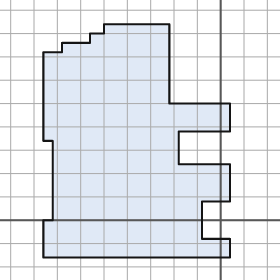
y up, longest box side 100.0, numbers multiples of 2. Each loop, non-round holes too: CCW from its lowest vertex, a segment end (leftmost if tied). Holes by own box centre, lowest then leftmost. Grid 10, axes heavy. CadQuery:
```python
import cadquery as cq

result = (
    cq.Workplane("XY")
    .moveTo(-76.0, -16.0)
    .lineTo(4.0, -16.0)
    .lineTo(4.0, -8.0)
    .lineTo(-8.0, -8.0)
    .lineTo(-8.0, 8.0)
    .lineTo(4.0, 8.0)
    .lineTo(4.0, 24.0)
    .lineTo(-18.0, 24.0)
    .lineTo(-18.0, 38.0)
    .lineTo(4.0, 38.0)
    .lineTo(4.0, 50.0)
    .lineTo(-22.0, 50.0)
    .lineTo(-22.0, 84.0)
    .lineTo(-50.0, 84.0)
    .lineTo(-50.0, 80.0)
    .lineTo(-56.0, 80.0)
    .lineTo(-56.0, 76.0)
    .lineTo(-68.0, 76.0)
    .lineTo(-68.0, 72.0)
    .lineTo(-76.0, 72.0)
    .lineTo(-76.0, 34.0)
    .lineTo(-72.0, 34.0)
    .lineTo(-72.0, 0.0)
    .lineTo(-76.0, 0.0)
    .close()
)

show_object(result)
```